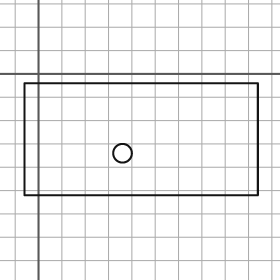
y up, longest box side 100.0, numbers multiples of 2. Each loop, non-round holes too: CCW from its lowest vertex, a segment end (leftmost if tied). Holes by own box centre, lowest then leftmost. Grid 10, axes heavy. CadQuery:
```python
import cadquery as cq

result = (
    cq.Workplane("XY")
    .moveTo(-6.0, -52.0)
    .lineTo(94.0, -52.0)
    .lineTo(94.0, -4.0)
    .lineTo(-6.0, -4.0)
    .close()
    .moveTo(36.0, -34.0)
    .circle(4.0)
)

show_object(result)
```